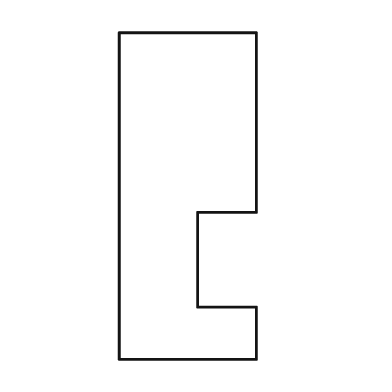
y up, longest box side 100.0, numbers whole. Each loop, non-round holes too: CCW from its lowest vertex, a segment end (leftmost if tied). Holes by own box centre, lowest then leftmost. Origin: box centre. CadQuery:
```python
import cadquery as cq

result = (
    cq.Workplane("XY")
    .moveTo(-21.0, -50.0)
    .lineTo(21.0, -50.0)
    .lineTo(21.0, -34.0)
    .lineTo(3.0, -34.0)
    .lineTo(3.0, -5.0)
    .lineTo(21.0, -5.0)
    .lineTo(21.0, 50.0)
    .lineTo(-21.0, 50.0)
    .close()
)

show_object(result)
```